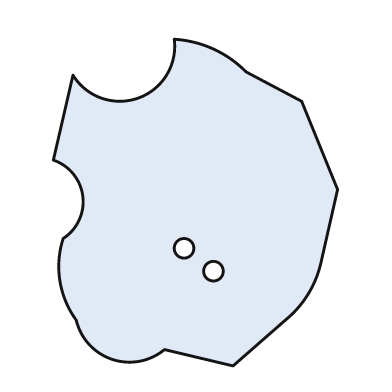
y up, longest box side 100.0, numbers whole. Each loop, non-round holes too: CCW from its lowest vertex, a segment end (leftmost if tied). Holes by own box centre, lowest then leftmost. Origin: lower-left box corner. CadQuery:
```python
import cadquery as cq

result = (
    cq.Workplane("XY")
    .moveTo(55.0, 0.0)
    .lineTo(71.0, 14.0)
    .threePointArc((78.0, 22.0), (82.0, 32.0))
    .lineTo(87.0, 54.0)
    .lineTo(76.0, 81.0)
    .lineTo(59.0, 90.0)
    .threePointArc((49.0, 97.0), (37.0, 100.0))
    .threePointArc((26.0, 82.0), (6.0, 89.0))
    .lineTo(0.0, 63.0)
    .threePointArc((9.0, 52.0), (3.0, 39.0))
    .threePointArc((2.0, 26.0), (7.0, 14.0))
    .threePointArc((18.0, 2.0), (34.0, 5.0))
    .close()
    .moveTo(49.0, 29.0)
    .circle(3.0)
    .moveTo(40.0, 36.0)
    .circle(3.0)
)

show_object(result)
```